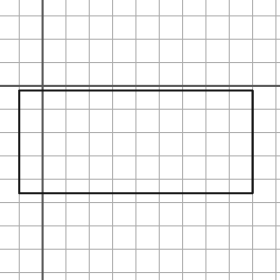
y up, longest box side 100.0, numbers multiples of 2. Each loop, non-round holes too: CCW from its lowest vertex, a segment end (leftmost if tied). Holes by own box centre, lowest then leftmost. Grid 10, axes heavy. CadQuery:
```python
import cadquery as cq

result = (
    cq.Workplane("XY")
    .moveTo(-10.0, -46.0)
    .lineTo(90.0, -46.0)
    .lineTo(90.0, -2.0)
    .lineTo(-10.0, -2.0)
    .close()
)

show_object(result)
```